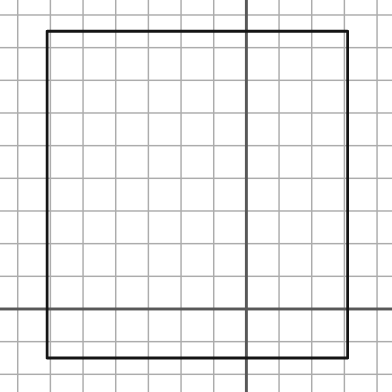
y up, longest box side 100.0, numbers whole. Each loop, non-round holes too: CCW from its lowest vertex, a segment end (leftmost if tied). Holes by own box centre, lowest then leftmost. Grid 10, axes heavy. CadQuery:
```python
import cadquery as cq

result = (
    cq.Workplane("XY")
    .moveTo(-61.0, -15.0)
    .lineTo(31.0, -15.0)
    .lineTo(31.0, 85.0)
    .lineTo(-61.0, 85.0)
    .close()
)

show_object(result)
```